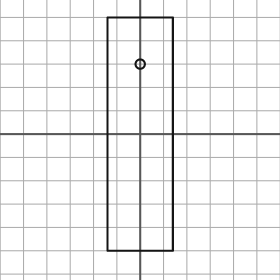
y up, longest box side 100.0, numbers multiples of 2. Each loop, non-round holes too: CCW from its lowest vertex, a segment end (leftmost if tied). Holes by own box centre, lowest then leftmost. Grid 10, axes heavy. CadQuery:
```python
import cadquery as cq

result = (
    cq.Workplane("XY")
    .moveTo(-14.0, -50.0)
    .lineTo(14.0, -50.0)
    .lineTo(14.0, 50.0)
    .lineTo(-14.0, 50.0)
    .close()
    .moveTo(0.0, 30.0)
    .circle(2.0)
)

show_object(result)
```